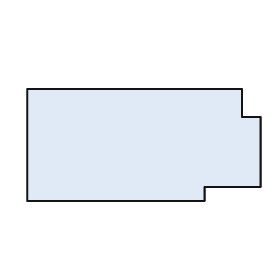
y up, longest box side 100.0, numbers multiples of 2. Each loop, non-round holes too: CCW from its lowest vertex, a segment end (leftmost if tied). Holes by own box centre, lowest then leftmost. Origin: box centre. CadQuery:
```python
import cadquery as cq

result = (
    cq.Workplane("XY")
    .moveTo(-50.0, -24.0)
    .lineTo(26.0, -24.0)
    .lineTo(26.0, -18.0)
    .lineTo(50.0, -18.0)
    .lineTo(50.0, 12.0)
    .lineTo(42.0, 12.0)
    .lineTo(42.0, 24.0)
    .lineTo(-50.0, 24.0)
    .close()
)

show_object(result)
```